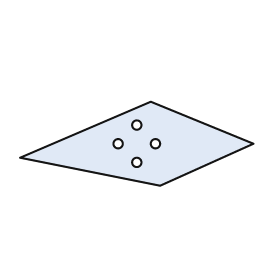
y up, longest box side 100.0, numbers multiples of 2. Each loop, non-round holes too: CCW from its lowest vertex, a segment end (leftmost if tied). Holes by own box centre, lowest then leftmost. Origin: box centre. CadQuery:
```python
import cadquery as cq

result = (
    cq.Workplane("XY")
    .moveTo(10.0, -18.0)
    .lineTo(50.0, 0.0)
    .lineTo(6.0, 18.0)
    .lineTo(-50.0, -6.0)
    .close()
    .moveTo(0.0, -8.0)
    .circle(2.0)
    .moveTo(-8.0, 0.0)
    .circle(2.0)
    .moveTo(8.0, 0.0)
    .circle(2.0)
    .moveTo(0.0, 8.0)
    .circle(2.0)
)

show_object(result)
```